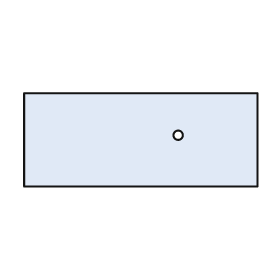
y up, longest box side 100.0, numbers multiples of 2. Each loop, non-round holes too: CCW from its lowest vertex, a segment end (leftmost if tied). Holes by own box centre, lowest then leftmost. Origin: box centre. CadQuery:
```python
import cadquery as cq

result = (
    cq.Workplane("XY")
    .moveTo(-50.0, -20.0)
    .lineTo(50.0, -20.0)
    .lineTo(50.0, 20.0)
    .lineTo(-50.0, 20.0)
    .close()
    .moveTo(16.0, 2.0)
    .circle(2.0)
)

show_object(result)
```